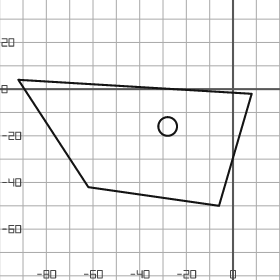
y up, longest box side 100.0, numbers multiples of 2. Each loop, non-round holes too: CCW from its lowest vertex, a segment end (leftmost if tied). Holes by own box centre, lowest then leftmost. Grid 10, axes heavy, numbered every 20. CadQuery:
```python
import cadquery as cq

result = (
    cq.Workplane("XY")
    .moveTo(-6.0, -50.0)
    .lineTo(8.0, -2.0)
    .lineTo(-92.0, 4.0)
    .lineTo(-62.0, -42.0)
    .close()
    .moveTo(-28.0, -16.0)
    .circle(4.0)
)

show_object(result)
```